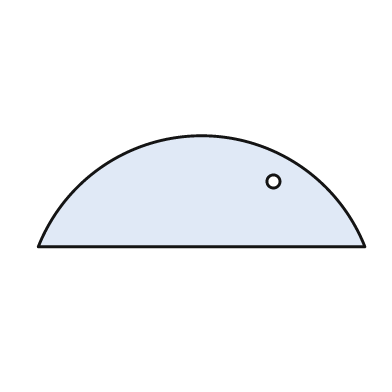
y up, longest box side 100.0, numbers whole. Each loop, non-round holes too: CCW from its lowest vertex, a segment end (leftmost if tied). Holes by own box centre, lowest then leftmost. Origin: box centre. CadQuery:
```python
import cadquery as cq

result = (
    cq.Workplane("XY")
    .moveTo(-50.0, -17.0)
    .lineTo(50.0, -17.0)
    .threePointArc((0.0, 17.0), (-50.0, -17.0))
    .close()
    .moveTo(22.0, 3.0)
    .circle(2.0)
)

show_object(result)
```